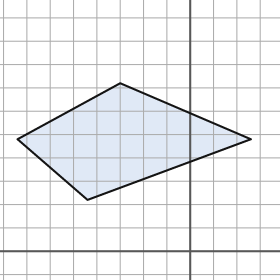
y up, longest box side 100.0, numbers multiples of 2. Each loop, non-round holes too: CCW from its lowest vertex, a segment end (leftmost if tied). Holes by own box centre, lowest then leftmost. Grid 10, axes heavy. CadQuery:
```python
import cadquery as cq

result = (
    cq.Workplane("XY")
    .moveTo(-44.0, 22.0)
    .lineTo(26.0, 48.0)
    .lineTo(-30.0, 72.0)
    .lineTo(-74.0, 48.0)
    .close()
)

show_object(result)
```